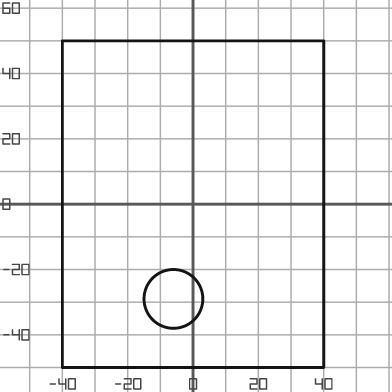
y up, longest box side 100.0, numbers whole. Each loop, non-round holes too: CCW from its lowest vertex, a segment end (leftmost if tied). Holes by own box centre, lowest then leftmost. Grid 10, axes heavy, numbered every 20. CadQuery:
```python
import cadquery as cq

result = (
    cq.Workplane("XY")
    .moveTo(-40.0, -50.0)
    .lineTo(40.0, -50.0)
    .lineTo(40.0, 50.0)
    .lineTo(-40.0, 50.0)
    .close()
    .moveTo(-6.0, -29.0)
    .circle(9.0)
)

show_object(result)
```